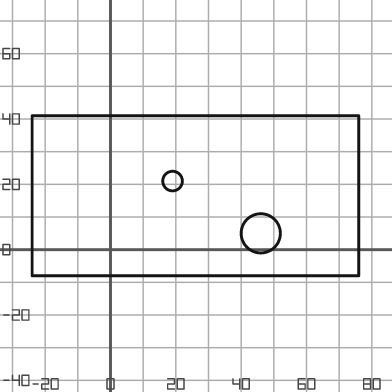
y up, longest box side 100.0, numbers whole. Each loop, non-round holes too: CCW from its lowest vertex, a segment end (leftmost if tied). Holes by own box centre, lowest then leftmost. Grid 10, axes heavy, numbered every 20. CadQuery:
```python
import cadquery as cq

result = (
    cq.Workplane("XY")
    .moveTo(-24.0, -8.0)
    .lineTo(76.0, -8.0)
    .lineTo(76.0, 41.0)
    .lineTo(-24.0, 41.0)
    .close()
    .moveTo(46.0, 5.0)
    .circle(6.0)
    .moveTo(19.0, 21.0)
    .circle(3.0)
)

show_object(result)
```